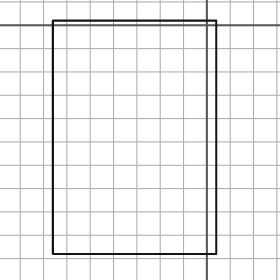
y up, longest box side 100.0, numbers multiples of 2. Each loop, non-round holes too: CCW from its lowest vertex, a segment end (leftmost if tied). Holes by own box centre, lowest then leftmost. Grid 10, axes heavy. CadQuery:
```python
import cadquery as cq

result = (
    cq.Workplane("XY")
    .moveTo(-66.0, -98.0)
    .lineTo(4.0, -98.0)
    .lineTo(4.0, 2.0)
    .lineTo(-66.0, 2.0)
    .close()
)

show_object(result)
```